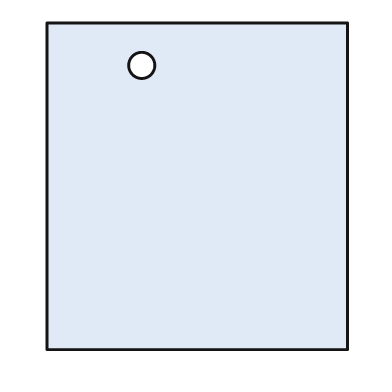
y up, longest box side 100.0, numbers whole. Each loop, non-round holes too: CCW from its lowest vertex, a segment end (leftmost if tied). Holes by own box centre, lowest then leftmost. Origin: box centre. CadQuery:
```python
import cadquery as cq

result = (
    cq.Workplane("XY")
    .moveTo(-46.0, -50.0)
    .lineTo(46.0, -50.0)
    .lineTo(46.0, 50.0)
    .lineTo(-46.0, 50.0)
    .close()
    .moveTo(-17.0, 37.0)
    .circle(4.0)
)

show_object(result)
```